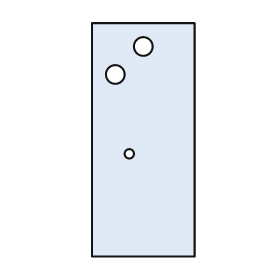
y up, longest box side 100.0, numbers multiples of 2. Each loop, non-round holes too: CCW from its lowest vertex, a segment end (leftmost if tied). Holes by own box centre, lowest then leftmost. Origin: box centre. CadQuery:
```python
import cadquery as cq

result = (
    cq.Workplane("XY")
    .moveTo(-22.0, -50.0)
    .lineTo(22.0, -50.0)
    .lineTo(22.0, 50.0)
    .lineTo(-22.0, 50.0)
    .close()
    .moveTo(-6.0, -6.0)
    .circle(2.0)
    .moveTo(-12.0, 28.0)
    .circle(4.0)
    .moveTo(0.0, 40.0)
    .circle(4.0)
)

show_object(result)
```